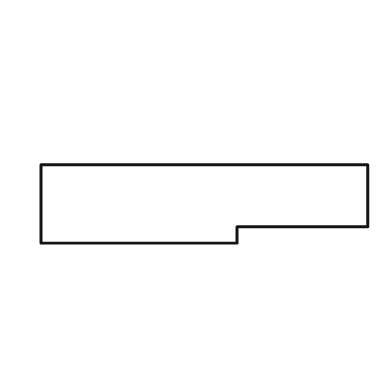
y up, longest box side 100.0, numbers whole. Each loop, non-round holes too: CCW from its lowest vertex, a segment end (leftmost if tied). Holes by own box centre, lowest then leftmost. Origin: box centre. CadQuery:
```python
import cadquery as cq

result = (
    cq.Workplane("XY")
    .moveTo(-50.0, -12.0)
    .lineTo(10.0, -12.0)
    .lineTo(10.0, -7.0)
    .lineTo(50.0, -7.0)
    .lineTo(50.0, 12.0)
    .lineTo(-50.0, 12.0)
    .close()
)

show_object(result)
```